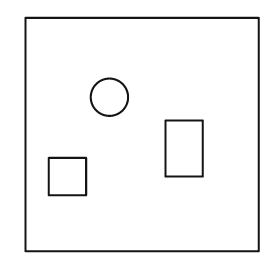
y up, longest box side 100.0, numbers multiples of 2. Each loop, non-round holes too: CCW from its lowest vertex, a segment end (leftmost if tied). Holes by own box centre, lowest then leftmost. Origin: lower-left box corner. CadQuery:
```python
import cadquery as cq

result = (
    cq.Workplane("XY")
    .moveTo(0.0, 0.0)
    .lineTo(100.0, 0.0)
    .lineTo(100.0, 100.0)
    .lineTo(0.0, 100.0)
    .close()
    .moveTo(10.0, 24.0)
    .lineTo(26.0, 24.0)
    .lineTo(26.0, 40.0)
    .lineTo(10.0, 40.0)
    .close()
    .moveTo(60.0, 32.0)
    .lineTo(76.0, 32.0)
    .lineTo(76.0, 56.0)
    .lineTo(60.0, 56.0)
    .close()
    .moveTo(36.0, 66.0)
    .circle(8.0)
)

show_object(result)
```